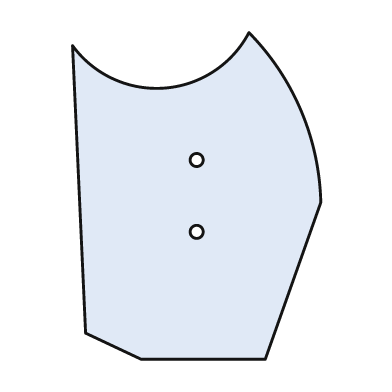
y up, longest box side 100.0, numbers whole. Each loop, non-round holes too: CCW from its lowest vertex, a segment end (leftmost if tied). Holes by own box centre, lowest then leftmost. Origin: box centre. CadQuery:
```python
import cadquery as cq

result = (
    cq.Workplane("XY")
    .moveTo(-17.0, -50.0)
    .lineTo(21.0, -50.0)
    .lineTo(38.0, -2.0)
    .threePointArc((32.0, 26.0), (16.0, 50.0))
    .threePointArc((-10.0, 33.0), (-38.0, 46.0))
    .lineTo(-34.0, -42.0)
    .close()
    .moveTo(0.0, -11.0)
    .circle(2.0)
    .moveTo(0.0, 11.0)
    .circle(2.0)
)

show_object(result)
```